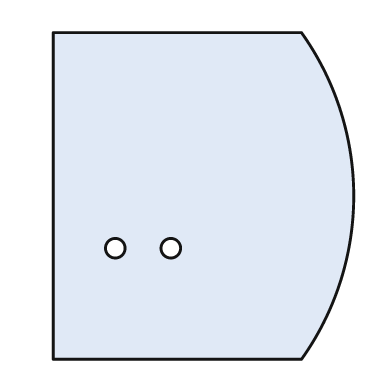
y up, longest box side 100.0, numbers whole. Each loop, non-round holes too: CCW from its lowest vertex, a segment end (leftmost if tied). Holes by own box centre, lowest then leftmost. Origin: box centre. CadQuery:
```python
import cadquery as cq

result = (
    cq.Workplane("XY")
    .moveTo(-46.0, -50.0)
    .lineTo(30.0, -50.0)
    .threePointArc((46.0, 0.0), (30.0, 50.0))
    .lineTo(-46.0, 50.0)
    .close()
    .moveTo(-27.0, -16.0)
    .circle(3.0)
    .moveTo(-10.0, -16.0)
    .circle(3.0)
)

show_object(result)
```